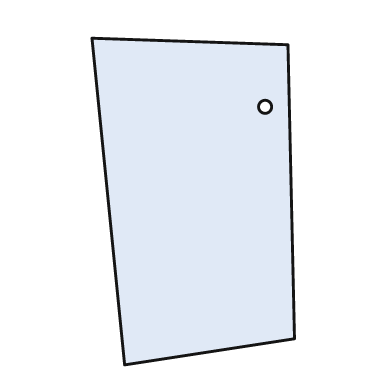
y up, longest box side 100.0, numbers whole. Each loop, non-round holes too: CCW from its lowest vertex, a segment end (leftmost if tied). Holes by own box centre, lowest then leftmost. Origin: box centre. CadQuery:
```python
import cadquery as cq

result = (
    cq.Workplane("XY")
    .moveTo(-21.0, -50.0)
    .lineTo(31.0, -42.0)
    .lineTo(29.0, 48.0)
    .lineTo(-31.0, 50.0)
    .close()
    .moveTo(22.0, 29.0)
    .circle(2.0)
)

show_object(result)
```